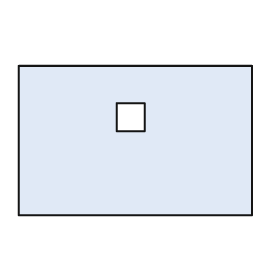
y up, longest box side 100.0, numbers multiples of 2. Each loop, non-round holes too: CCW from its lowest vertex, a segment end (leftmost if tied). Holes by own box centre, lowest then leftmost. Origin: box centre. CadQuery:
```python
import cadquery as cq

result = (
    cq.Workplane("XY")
    .moveTo(-50.0, -32.0)
    .lineTo(50.0, -32.0)
    .lineTo(50.0, 32.0)
    .lineTo(-50.0, 32.0)
    .close()
    .moveTo(-8.0, 4.0)
    .lineTo(4.0, 4.0)
    .lineTo(4.0, 16.0)
    .lineTo(-8.0, 16.0)
    .close()
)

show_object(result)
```